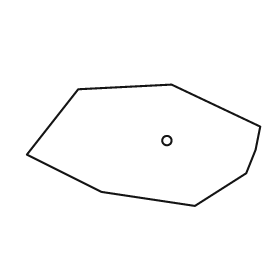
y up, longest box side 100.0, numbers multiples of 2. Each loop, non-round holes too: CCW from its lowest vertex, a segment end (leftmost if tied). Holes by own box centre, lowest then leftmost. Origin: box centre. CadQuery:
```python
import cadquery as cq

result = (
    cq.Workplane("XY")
    .moveTo(22.0, -26.0)
    .lineTo(44.0, -12.0)
    .lineTo(48.0, -2.0)
    .lineTo(50.0, 8.0)
    .lineTo(12.0, 26.0)
    .lineTo(-28.0, 24.0)
    .lineTo(-50.0, -4.0)
    .lineTo(-18.0, -20.0)
    .close()
    .moveTo(10.0, 2.0)
    .circle(2.0)
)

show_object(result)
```